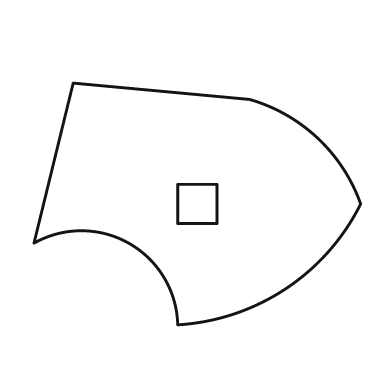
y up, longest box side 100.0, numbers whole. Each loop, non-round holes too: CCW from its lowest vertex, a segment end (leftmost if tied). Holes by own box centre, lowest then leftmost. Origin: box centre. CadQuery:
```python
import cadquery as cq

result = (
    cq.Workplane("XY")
    .moveTo(-6.0, -37.0)
    .threePointArc((27.0, -26.0), (50.0, 0.0))
    .threePointArc((37.0, 20.0), (16.0, 32.0))
    .lineTo(-38.0, 37.0)
    .lineTo(-50.0, -12.0)
    .threePointArc((-21.0, -12.0), (-6.0, -37.0))
    .close()
    .moveTo(-6.0, -6.0)
    .lineTo(6.0, -6.0)
    .lineTo(6.0, 6.0)
    .lineTo(-6.0, 6.0)
    .close()
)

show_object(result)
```